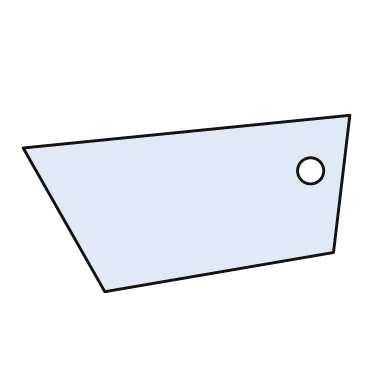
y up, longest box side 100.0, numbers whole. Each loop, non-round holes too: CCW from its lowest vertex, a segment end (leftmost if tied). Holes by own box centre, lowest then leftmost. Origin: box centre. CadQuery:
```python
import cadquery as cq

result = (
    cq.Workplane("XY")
    .moveTo(-25.0, -27.0)
    .lineTo(45.0, -15.0)
    .lineTo(50.0, 27.0)
    .lineTo(-50.0, 17.0)
    .close()
    .moveTo(38.0, 10.0)
    .circle(4.0)
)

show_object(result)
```